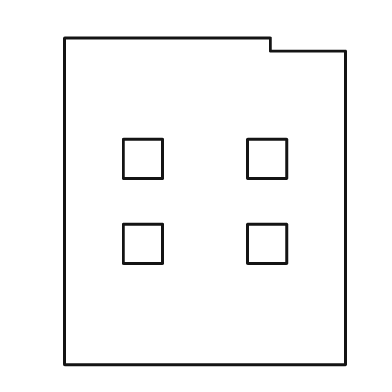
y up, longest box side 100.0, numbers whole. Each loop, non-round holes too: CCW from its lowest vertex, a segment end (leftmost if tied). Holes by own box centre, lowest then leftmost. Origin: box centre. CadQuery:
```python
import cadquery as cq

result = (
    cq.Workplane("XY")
    .moveTo(-43.0, -50.0)
    .lineTo(43.0, -50.0)
    .lineTo(43.0, 46.0)
    .lineTo(20.0, 46.0)
    .lineTo(20.0, 50.0)
    .lineTo(-43.0, 50.0)
    .close()
    .moveTo(-25.0, -19.0)
    .lineTo(-13.0, -19.0)
    .lineTo(-13.0, -7.0)
    .lineTo(-25.0, -7.0)
    .close()
    .moveTo(13.0, -19.0)
    .lineTo(25.0, -19.0)
    .lineTo(25.0, -7.0)
    .lineTo(13.0, -7.0)
    .close()
    .moveTo(-25.0, 7.0)
    .lineTo(-13.0, 7.0)
    .lineTo(-13.0, 19.0)
    .lineTo(-25.0, 19.0)
    .close()
    .moveTo(13.0, 7.0)
    .lineTo(25.0, 7.0)
    .lineTo(25.0, 19.0)
    .lineTo(13.0, 19.0)
    .close()
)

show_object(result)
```